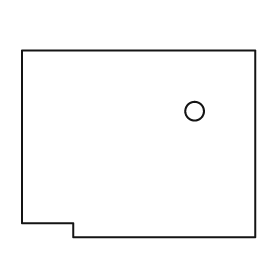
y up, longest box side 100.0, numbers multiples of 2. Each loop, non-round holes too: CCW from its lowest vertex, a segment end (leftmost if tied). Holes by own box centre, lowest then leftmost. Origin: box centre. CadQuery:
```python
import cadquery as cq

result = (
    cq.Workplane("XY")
    .moveTo(-28.0, -40.0)
    .lineTo(50.0, -40.0)
    .lineTo(50.0, 40.0)
    .lineTo(-50.0, 40.0)
    .lineTo(-50.0, -34.0)
    .lineTo(-28.0, -34.0)
    .close()
    .moveTo(24.0, 14.0)
    .circle(4.0)
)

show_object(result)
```